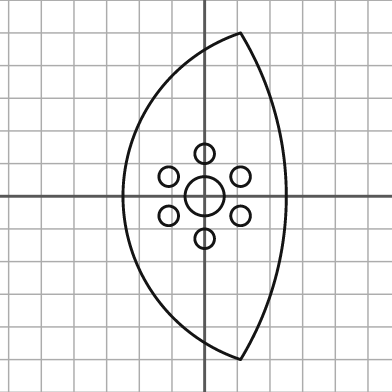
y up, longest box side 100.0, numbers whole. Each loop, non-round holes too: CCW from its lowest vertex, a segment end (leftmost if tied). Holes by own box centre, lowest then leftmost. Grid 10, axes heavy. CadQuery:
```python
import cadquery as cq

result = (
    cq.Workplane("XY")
    .moveTo(11.0, -50.0)
    .threePointArc((25.0, 0.0), (11.0, 50.0))
    .threePointArc((-25.0, 0.0), (11.0, -50.0))
    .close()
    .moveTo(0.0, -13.0)
    .circle(3.0)
    .moveTo(-11.0, -6.0)
    .circle(3.0)
    .moveTo(11.0, -6.0)
    .circle(3.0)
    .moveTo(0.0, 0.0)
    .circle(6.0)
    .moveTo(-11.0, 6.0)
    .circle(3.0)
    .moveTo(11.0, 6.0)
    .circle(3.0)
    .moveTo(0.0, 13.0)
    .circle(3.0)
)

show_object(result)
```